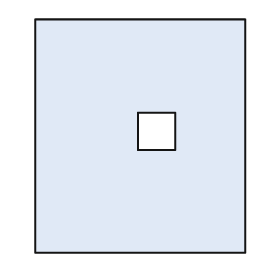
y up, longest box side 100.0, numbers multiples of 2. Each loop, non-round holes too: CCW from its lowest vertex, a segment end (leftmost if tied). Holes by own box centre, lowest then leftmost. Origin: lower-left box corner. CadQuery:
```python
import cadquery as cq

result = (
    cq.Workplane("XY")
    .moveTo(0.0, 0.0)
    .lineTo(90.0, 0.0)
    .lineTo(90.0, 100.0)
    .lineTo(0.0, 100.0)
    .close()
    .moveTo(44.0, 44.0)
    .lineTo(60.0, 44.0)
    .lineTo(60.0, 60.0)
    .lineTo(44.0, 60.0)
    .close()
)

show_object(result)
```